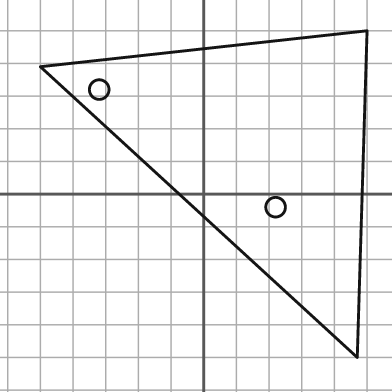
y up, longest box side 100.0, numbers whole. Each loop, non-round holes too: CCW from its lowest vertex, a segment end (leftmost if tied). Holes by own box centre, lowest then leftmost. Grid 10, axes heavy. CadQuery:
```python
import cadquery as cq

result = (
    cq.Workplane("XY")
    .moveTo(47.0, -50.0)
    .lineTo(50.0, 50.0)
    .lineTo(-50.0, 39.0)
    .close()
    .moveTo(22.0, -4.0)
    .circle(3.0)
    .moveTo(-32.0, 32.0)
    .circle(3.0)
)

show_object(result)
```